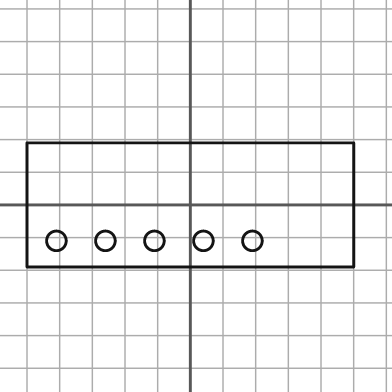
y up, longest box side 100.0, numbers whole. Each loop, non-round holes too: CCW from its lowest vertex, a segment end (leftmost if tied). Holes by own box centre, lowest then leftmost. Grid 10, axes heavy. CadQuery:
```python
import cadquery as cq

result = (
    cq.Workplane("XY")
    .moveTo(-50.0, -19.0)
    .lineTo(50.0, -19.0)
    .lineTo(50.0, 19.0)
    .lineTo(-50.0, 19.0)
    .close()
    .moveTo(-41.0, -11.0)
    .circle(3.0)
    .moveTo(-26.0, -11.0)
    .circle(3.0)
    .moveTo(-11.0, -11.0)
    .circle(3.0)
    .moveTo(4.0, -11.0)
    .circle(3.0)
    .moveTo(19.0, -11.0)
    .circle(3.0)
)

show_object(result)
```